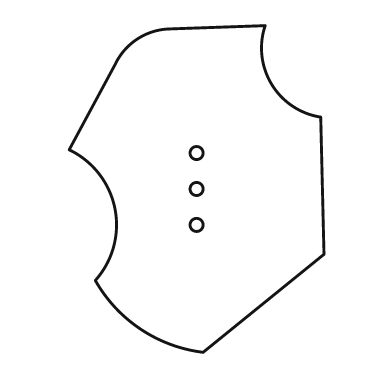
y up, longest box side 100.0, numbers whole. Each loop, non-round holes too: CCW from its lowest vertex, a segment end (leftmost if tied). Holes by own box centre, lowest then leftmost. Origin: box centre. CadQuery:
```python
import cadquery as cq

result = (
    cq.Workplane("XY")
    .moveTo(2.0, -50.0)
    .lineTo(39.0, -20.0)
    .lineTo(38.0, 22.0)
    .threePointArc((23.0, 32.0), (21.0, 50.0))
    .lineTo(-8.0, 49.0)
    .threePointArc((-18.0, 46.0), (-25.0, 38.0))
    .lineTo(-39.0, 12.0)
    .threePointArc((-25.0, -6.0), (-31.0, -28.0))
    .threePointArc((-17.0, -43.0), (2.0, -50.0))
    .close()
    .moveTo(0.0, -11.0)
    .circle(2.0)
    .moveTo(0.0, 0.0)
    .circle(2.0)
    .moveTo(0.0, 11.0)
    .circle(2.0)
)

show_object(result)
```